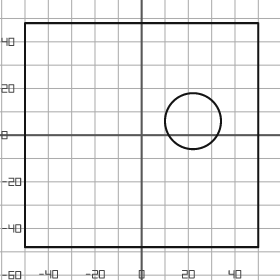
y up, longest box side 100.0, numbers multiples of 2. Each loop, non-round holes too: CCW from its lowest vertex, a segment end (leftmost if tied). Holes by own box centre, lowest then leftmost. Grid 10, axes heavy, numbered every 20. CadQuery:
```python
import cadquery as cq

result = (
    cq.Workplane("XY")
    .moveTo(-50.0, -48.0)
    .lineTo(50.0, -48.0)
    .lineTo(50.0, 48.0)
    .lineTo(-50.0, 48.0)
    .close()
    .moveTo(22.0, 6.0)
    .circle(12.0)
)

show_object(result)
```